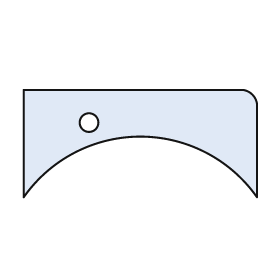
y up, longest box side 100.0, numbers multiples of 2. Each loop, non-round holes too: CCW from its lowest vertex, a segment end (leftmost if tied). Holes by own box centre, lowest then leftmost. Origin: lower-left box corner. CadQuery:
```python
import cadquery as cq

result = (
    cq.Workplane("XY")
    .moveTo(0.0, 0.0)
    .threePointArc((50.0, 26.0), (100.0, 0.0))
    .lineTo(100.0, 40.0)
    .threePointArc((98.0, 44.0), (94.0, 46.0))
    .lineTo(0.0, 46.0)
    .close()
    .moveTo(28.0, 32.0)
    .circle(4.0)
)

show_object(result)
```